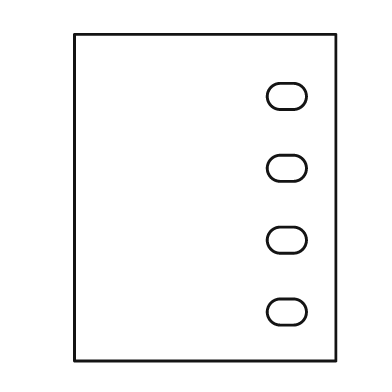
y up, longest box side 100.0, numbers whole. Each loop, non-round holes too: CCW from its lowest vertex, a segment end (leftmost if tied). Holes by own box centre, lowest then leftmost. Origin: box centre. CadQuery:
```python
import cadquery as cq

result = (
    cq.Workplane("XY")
    .moveTo(-40.0, -50.0)
    .lineTo(40.0, -50.0)
    .lineTo(40.0, 50.0)
    .lineTo(-40.0, 50.0)
    .close()
    .moveTo(23.0, -39.0)
    .lineTo(27.0, -39.0)
    .threePointArc((31.0, -35.0), (27.0, -31.0))
    .lineTo(23.0, -31.0)
    .threePointArc((19.0, -35.0), (23.0, -39.0))
    .close()
    .moveTo(23.0, -17.0)
    .lineTo(27.0, -17.0)
    .threePointArc((31.0, -13.0), (27.0, -9.0))
    .lineTo(23.0, -9.0)
    .threePointArc((19.0, -13.0), (23.0, -17.0))
    .close()
    .moveTo(23.0, 5.0)
    .lineTo(27.0, 5.0)
    .threePointArc((31.0, 9.0), (27.0, 13.0))
    .lineTo(23.0, 13.0)
    .threePointArc((19.0, 9.0), (23.0, 5.0))
    .close()
    .moveTo(23.0, 27.0)
    .lineTo(27.0, 27.0)
    .threePointArc((31.0, 31.0), (27.0, 35.0))
    .lineTo(23.0, 35.0)
    .threePointArc((19.0, 31.0), (23.0, 27.0))
    .close()
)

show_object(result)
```